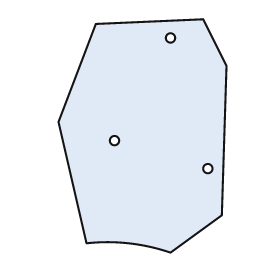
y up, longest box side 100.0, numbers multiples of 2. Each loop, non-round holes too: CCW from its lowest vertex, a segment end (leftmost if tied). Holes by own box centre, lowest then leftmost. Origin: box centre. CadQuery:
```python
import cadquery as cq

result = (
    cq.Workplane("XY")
    .moveTo(12.0, -50.0)
    .lineTo(34.0, -34.0)
    .lineTo(36.0, 30.0)
    .lineTo(26.0, 50.0)
    .lineTo(-20.0, 48.0)
    .lineTo(-36.0, 6.0)
    .lineTo(-24.0, -46.0)
    .threePointArc((-6.0, -46.0), (12.0, -50.0))
    .close()
    .moveTo(28.0, -14.0)
    .circle(2.0)
    .moveTo(-12.0, -2.0)
    .circle(2.0)
    .moveTo(12.0, 42.0)
    .circle(2.0)
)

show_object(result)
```